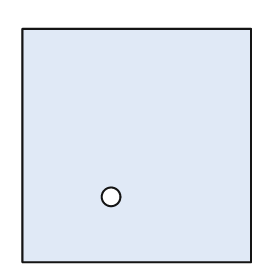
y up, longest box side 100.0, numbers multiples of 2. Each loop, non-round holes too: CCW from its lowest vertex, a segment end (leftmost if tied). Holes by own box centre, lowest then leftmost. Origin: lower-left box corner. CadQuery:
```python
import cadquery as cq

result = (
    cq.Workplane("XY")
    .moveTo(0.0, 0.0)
    .lineTo(98.0, 0.0)
    .lineTo(98.0, 100.0)
    .lineTo(0.0, 100.0)
    .close()
    .moveTo(38.0, 28.0)
    .circle(4.0)
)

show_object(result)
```